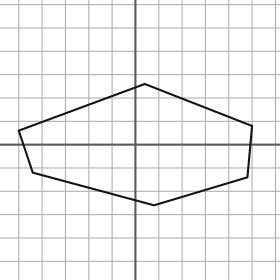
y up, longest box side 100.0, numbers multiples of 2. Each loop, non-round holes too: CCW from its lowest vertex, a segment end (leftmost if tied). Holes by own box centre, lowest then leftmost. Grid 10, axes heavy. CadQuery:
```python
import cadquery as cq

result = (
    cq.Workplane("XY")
    .moveTo(8.0, -26.0)
    .lineTo(48.0, -14.0)
    .lineTo(50.0, 8.0)
    .lineTo(4.0, 26.0)
    .lineTo(-50.0, 6.0)
    .lineTo(-44.0, -12.0)
    .close()
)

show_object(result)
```